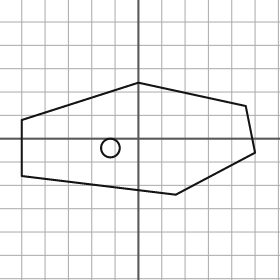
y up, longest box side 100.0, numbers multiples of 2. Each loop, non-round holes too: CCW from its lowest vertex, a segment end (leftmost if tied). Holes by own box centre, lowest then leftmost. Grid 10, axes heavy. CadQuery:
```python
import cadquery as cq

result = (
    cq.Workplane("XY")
    .moveTo(16.0, -24.0)
    .lineTo(50.0, -6.0)
    .lineTo(46.0, 14.0)
    .lineTo(0.0, 24.0)
    .lineTo(-50.0, 8.0)
    .lineTo(-50.0, -16.0)
    .close()
    .moveTo(-12.0, -4.0)
    .circle(4.0)
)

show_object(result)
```